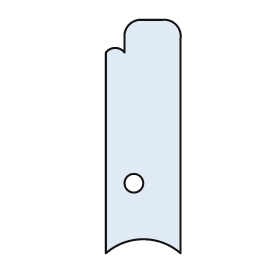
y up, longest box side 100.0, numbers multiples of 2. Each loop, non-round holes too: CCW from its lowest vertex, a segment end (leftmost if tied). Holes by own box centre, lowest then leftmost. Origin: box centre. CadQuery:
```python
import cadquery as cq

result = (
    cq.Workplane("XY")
    .moveTo(-16.0, -50.0)
    .threePointArc((0.0, -44.0), (16.0, -50.0))
    .lineTo(16.0, 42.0)
    .threePointArc((14.0, 48.0), (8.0, 50.0))
    .lineTo(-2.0, 50.0)
    .threePointArc((-6.0, 48.0), (-8.0, 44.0))
    .lineTo(-8.0, 36.0)
    .threePointArc((-12.0, 38.0), (-16.0, 36.0))
    .close()
    .moveTo(-4.0, -20.0)
    .circle(4.0)
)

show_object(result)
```